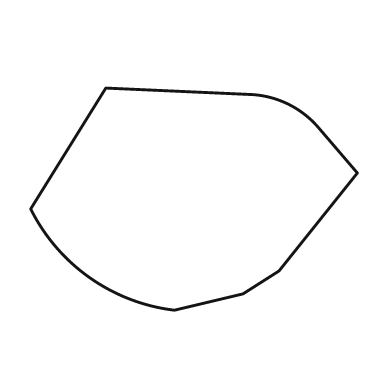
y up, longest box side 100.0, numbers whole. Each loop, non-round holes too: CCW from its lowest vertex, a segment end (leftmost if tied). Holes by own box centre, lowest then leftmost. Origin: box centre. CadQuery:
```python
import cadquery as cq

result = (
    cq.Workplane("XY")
    .moveTo(-6.0, -34.0)
    .lineTo(15.0, -29.0)
    .lineTo(26.0, -22.0)
    .lineTo(50.0, 8.0)
    .lineTo(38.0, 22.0)
    .threePointArc((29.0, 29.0), (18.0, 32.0))
    .lineTo(-27.0, 34.0)
    .lineTo(-50.0, -3.0)
    .threePointArc((-32.0, -24.0), (-6.0, -34.0))
    .close()
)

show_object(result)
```